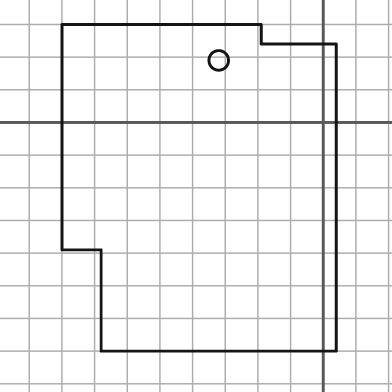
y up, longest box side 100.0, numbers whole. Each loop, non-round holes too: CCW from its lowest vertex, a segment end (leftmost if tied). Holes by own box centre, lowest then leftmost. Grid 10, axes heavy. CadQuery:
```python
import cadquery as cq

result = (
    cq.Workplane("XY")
    .moveTo(-68.0, -70.0)
    .lineTo(4.0, -70.0)
    .lineTo(4.0, 24.0)
    .lineTo(-19.0, 24.0)
    .lineTo(-19.0, 30.0)
    .lineTo(-80.0, 30.0)
    .lineTo(-80.0, -39.0)
    .lineTo(-68.0, -39.0)
    .close()
    .moveTo(-32.0, 19.0)
    .circle(3.0)
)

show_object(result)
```